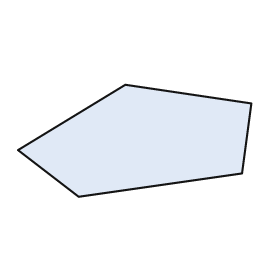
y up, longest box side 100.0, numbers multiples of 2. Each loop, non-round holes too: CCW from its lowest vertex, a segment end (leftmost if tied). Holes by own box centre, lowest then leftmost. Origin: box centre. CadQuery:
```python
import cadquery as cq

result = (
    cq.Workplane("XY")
    .moveTo(-24.0, -24.0)
    .lineTo(46.0, -14.0)
    .lineTo(50.0, 16.0)
    .lineTo(-4.0, 24.0)
    .lineTo(-50.0, -4.0)
    .close()
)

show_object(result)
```